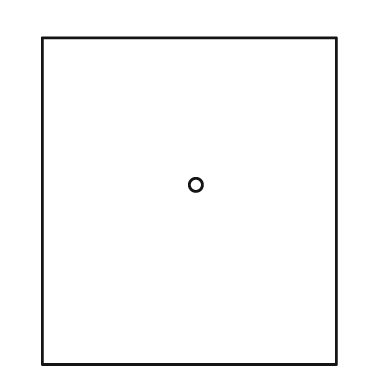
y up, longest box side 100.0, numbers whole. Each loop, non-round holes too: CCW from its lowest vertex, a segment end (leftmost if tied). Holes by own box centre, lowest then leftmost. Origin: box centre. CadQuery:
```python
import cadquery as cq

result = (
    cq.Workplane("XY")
    .moveTo(-45.0, -50.0)
    .lineTo(45.0, -50.0)
    .lineTo(45.0, 50.0)
    .lineTo(-45.0, 50.0)
    .close()
    .moveTo(2.0, 5.0)
    .circle(2.0)
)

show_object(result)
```